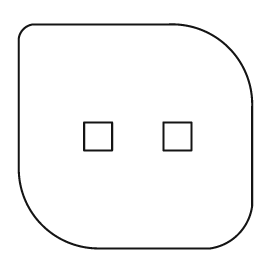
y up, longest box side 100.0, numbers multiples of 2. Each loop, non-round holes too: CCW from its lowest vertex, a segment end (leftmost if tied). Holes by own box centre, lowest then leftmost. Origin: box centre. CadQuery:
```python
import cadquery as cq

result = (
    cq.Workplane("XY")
    .moveTo(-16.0, -48.0)
    .lineTo(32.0, -48.0)
    .threePointArc((44.0, -42.0), (50.0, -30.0))
    .lineTo(50.0, 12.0)
    .threePointArc((40.0, 38.0), (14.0, 48.0))
    .lineTo(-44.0, 48.0)
    .threePointArc((-48.0, 46.0), (-50.0, 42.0))
    .lineTo(-50.0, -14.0)
    .threePointArc((-40.0, -38.0), (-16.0, -48.0))
    .close()
    .moveTo(-22.0, -6.0)
    .lineTo(-10.0, -6.0)
    .lineTo(-10.0, 6.0)
    .lineTo(-22.0, 6.0)
    .close()
    .moveTo(12.0, -6.0)
    .lineTo(24.0, -6.0)
    .lineTo(24.0, 6.0)
    .lineTo(12.0, 6.0)
    .close()
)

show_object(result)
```